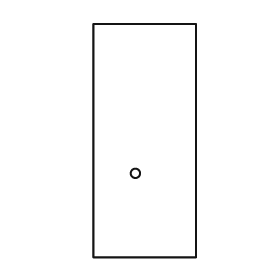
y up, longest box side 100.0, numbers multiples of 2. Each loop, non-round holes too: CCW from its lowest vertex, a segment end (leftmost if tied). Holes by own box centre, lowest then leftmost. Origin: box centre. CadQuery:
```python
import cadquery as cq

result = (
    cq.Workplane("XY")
    .moveTo(-22.0, -50.0)
    .lineTo(22.0, -50.0)
    .lineTo(22.0, 50.0)
    .lineTo(-22.0, 50.0)
    .close()
    .moveTo(-4.0, -14.0)
    .circle(2.0)
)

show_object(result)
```